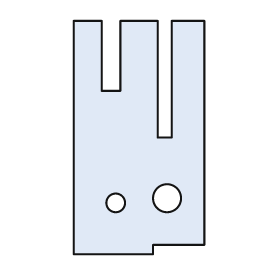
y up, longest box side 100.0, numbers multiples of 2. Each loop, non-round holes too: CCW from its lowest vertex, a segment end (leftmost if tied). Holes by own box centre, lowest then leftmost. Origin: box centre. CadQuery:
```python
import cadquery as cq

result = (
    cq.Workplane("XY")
    .moveTo(-28.0, -50.0)
    .lineTo(6.0, -50.0)
    .lineTo(6.0, -46.0)
    .lineTo(28.0, -46.0)
    .lineTo(28.0, 50.0)
    .lineTo(14.0, 50.0)
    .lineTo(14.0, 0.0)
    .lineTo(8.0, 0.0)
    .lineTo(8.0, 50.0)
    .lineTo(-8.0, 50.0)
    .lineTo(-8.0, 20.0)
    .lineTo(-16.0, 20.0)
    .lineTo(-16.0, 50.0)
    .lineTo(-28.0, 50.0)
    .close()
    .moveTo(-10.0, -28.0)
    .circle(4.0)
    .moveTo(12.0, -26.0)
    .circle(6.0)
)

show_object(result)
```